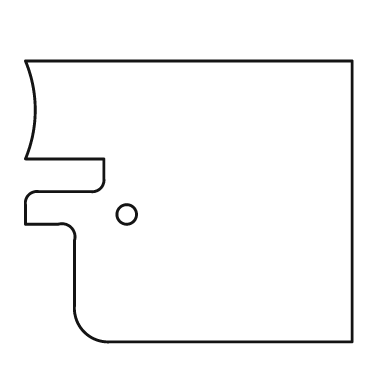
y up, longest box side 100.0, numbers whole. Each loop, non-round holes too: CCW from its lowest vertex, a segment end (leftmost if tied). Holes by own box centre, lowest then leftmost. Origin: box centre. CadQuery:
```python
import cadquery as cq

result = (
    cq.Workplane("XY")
    .moveTo(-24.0, -43.0)
    .lineTo(50.0, -43.0)
    .lineTo(50.0, 43.0)
    .lineTo(-50.0, 43.0)
    .threePointArc((-47.0, 28.0), (-50.0, 13.0))
    .lineTo(-26.0, 13.0)
    .lineTo(-26.0, 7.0)
    .threePointArc((-27.0, 4.0), (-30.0, 3.0))
    .lineTo(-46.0, 3.0)
    .threePointArc((-49.0, 2.0), (-50.0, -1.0))
    .lineTo(-50.0, -7.0)
    .lineTo(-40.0, -7.0)
    .threePointArc((-36.0, -8.0), (-35.0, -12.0))
    .lineTo(-35.0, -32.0)
    .threePointArc((-32.0, -40.0), (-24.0, -43.0))
    .close()
    .moveTo(-19.0, -4.0)
    .circle(3.0)
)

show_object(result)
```